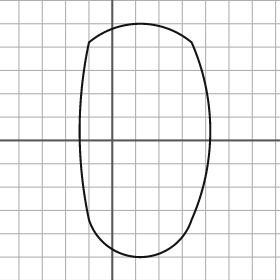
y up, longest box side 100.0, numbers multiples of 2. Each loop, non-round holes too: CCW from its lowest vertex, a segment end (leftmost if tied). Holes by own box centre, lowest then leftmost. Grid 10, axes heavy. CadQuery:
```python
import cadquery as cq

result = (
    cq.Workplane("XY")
    .moveTo(-10.0, -34.0)
    .threePointArc((12.0, -50.0), (34.0, -34.0))
    .threePointArc((42.0, 4.0), (34.0, 42.0))
    .threePointArc((12.0, 50.0), (-10.0, 42.0))
    .threePointArc((-14.0, 4.0), (-10.0, -34.0))
    .close()
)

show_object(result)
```